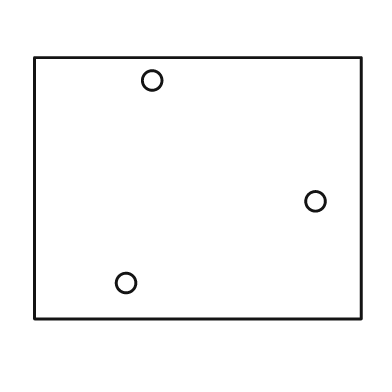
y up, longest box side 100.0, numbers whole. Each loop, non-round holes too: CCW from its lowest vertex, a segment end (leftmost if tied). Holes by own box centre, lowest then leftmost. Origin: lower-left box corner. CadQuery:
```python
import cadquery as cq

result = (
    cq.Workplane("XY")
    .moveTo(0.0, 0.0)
    .lineTo(100.0, 0.0)
    .lineTo(100.0, 80.0)
    .lineTo(0.0, 80.0)
    .close()
    .moveTo(28.0, 11.0)
    .circle(3.0)
    .moveTo(86.0, 36.0)
    .circle(3.0)
    .moveTo(36.0, 73.0)
    .circle(3.0)
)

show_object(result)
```